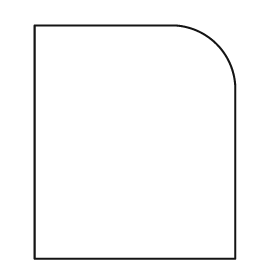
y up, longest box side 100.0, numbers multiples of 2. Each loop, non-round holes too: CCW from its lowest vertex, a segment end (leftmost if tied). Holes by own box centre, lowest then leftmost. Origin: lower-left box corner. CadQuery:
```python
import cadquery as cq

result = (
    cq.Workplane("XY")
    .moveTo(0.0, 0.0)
    .lineTo(86.0, 0.0)
    .lineTo(86.0, 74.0)
    .threePointArc((78.0, 92.0), (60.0, 100.0))
    .lineTo(0.0, 100.0)
    .close()
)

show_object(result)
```